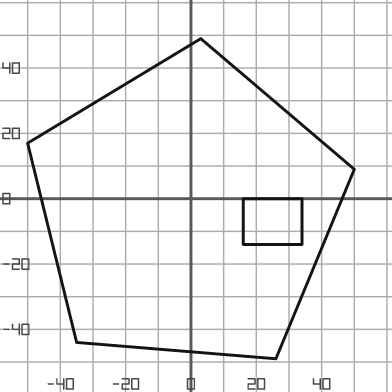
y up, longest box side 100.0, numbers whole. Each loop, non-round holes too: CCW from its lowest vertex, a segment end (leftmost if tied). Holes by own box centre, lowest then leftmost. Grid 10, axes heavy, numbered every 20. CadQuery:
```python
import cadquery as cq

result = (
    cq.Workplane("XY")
    .moveTo(26.0, -49.0)
    .lineTo(50.0, 9.0)
    .lineTo(3.0, 49.0)
    .lineTo(-50.0, 17.0)
    .lineTo(-35.0, -44.0)
    .close()
    .moveTo(16.0, -14.0)
    .lineTo(34.0, -14.0)
    .lineTo(34.0, 0.0)
    .lineTo(16.0, 0.0)
    .close()
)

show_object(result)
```